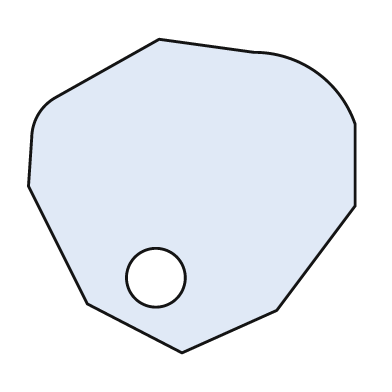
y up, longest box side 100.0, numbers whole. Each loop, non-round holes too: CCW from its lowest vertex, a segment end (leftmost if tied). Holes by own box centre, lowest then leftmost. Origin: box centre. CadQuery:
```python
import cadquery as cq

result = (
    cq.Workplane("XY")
    .moveTo(-3.0, -48.0)
    .lineTo(26.0, -35.0)
    .lineTo(50.0, -3.0)
    .lineTo(50.0, 22.0)
    .threePointArc((38.0, 38.0), (19.0, 44.0))
    .lineTo(-10.0, 48.0)
    .lineTo(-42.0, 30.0)
    .threePointArc((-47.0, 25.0), (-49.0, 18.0))
    .lineTo(-50.0, 3.0)
    .lineTo(-32.0, -33.0)
    .close()
    .moveTo(-11.0, -25.0)
    .circle(9.0)
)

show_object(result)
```